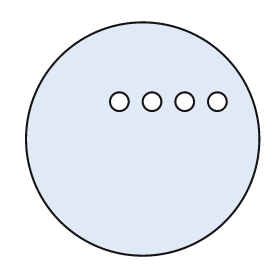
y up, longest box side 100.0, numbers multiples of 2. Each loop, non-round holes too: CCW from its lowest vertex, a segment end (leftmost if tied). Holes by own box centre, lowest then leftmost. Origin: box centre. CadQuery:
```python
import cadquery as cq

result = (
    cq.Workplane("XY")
    .moveTo(0.0, 0.0)
    .circle(50.0)
    .moveTo(-10.0, 16.0)
    .circle(4.0)
    .moveTo(4.0, 16.0)
    .circle(4.0)
    .moveTo(18.0, 16.0)
    .circle(4.0)
    .moveTo(32.0, 16.0)
    .circle(4.0)
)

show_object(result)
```